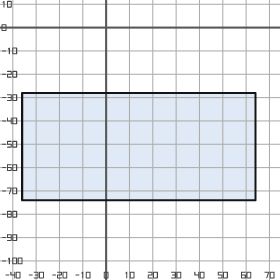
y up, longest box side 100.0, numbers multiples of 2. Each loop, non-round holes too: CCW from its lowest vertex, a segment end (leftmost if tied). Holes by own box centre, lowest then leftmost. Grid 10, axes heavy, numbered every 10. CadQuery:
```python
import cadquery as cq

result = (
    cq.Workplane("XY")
    .moveTo(-36.0, -74.0)
    .lineTo(64.0, -74.0)
    .lineTo(64.0, -28.0)
    .lineTo(-36.0, -28.0)
    .close()
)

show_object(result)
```